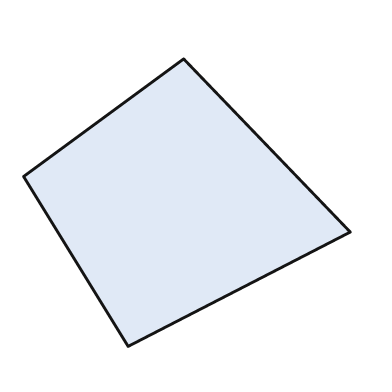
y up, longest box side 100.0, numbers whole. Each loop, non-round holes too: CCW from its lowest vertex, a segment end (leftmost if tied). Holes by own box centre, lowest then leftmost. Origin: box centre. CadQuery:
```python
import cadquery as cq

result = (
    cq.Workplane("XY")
    .moveTo(-18.0, -44.0)
    .lineTo(50.0, -9.0)
    .lineTo(-1.0, 44.0)
    .lineTo(-50.0, 8.0)
    .close()
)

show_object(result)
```